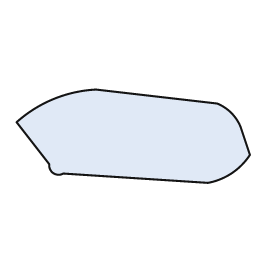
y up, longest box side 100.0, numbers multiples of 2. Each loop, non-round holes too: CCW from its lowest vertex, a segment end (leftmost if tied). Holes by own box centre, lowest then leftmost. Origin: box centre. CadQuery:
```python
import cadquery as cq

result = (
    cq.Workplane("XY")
    .moveTo(32.0, -20.0)
    .threePointArc((42.0, -16.0), (50.0, -8.0))
    .lineTo(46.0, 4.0)
    .threePointArc((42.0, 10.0), (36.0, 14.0))
    .lineTo(-16.0, 20.0)
    .threePointArc((-34.0, 16.0), (-50.0, 6.0))
    .lineTo(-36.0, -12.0)
    .threePointArc((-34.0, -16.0), (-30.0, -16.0))
    .close()
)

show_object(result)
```